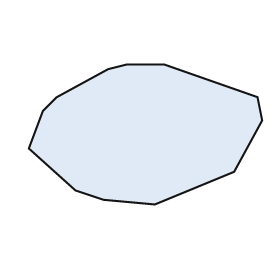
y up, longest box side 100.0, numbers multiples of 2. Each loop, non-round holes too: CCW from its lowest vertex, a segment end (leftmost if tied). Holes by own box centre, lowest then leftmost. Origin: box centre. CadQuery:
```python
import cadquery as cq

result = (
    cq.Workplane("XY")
    .moveTo(4.0, -30.0)
    .lineTo(38.0, -16.0)
    .lineTo(50.0, 6.0)
    .lineTo(48.0, 16.0)
    .lineTo(8.0, 30.0)
    .lineTo(-8.0, 30.0)
    .lineTo(-16.0, 28.0)
    .lineTo(-38.0, 16.0)
    .lineTo(-44.0, 10.0)
    .lineTo(-50.0, -6.0)
    .lineTo(-30.0, -24.0)
    .lineTo(-18.0, -28.0)
    .close()
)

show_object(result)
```